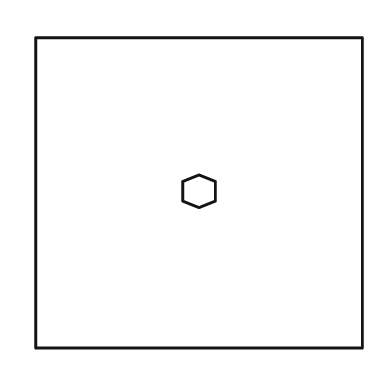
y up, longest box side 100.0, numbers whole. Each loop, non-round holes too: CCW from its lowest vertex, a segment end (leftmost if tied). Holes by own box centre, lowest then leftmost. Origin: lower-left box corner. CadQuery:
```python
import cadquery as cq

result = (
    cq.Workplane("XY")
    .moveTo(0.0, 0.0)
    .lineTo(100.0, 0.0)
    .lineTo(100.0, 95.0)
    .lineTo(0.0, 95.0)
    .close()
    .moveTo(50.0, 43.0)
    .lineTo(55.0, 45.0)
    .lineTo(55.0, 51.0)
    .lineTo(50.0, 53.0)
    .lineTo(45.0, 51.0)
    .lineTo(45.0, 45.0)
    .close()
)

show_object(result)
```